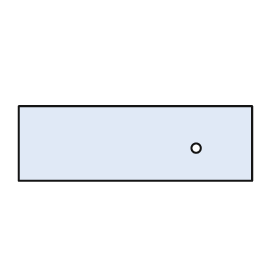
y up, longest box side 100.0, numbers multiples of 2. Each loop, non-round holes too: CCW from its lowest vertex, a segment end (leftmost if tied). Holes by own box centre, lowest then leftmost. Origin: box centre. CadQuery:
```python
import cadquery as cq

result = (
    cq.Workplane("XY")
    .moveTo(-50.0, -16.0)
    .lineTo(50.0, -16.0)
    .lineTo(50.0, 16.0)
    .lineTo(-50.0, 16.0)
    .close()
    .moveTo(26.0, -2.0)
    .circle(2.0)
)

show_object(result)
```